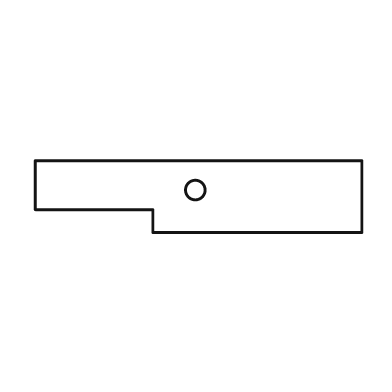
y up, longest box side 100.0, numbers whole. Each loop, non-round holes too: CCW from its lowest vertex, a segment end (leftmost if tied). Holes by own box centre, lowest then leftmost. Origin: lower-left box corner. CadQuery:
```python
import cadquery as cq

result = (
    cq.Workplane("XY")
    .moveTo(36.0, 0.0)
    .lineTo(100.0, 0.0)
    .lineTo(100.0, 22.0)
    .lineTo(0.0, 22.0)
    .lineTo(0.0, 7.0)
    .lineTo(36.0, 7.0)
    .close()
    .moveTo(49.0, 13.0)
    .circle(3.0)
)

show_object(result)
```